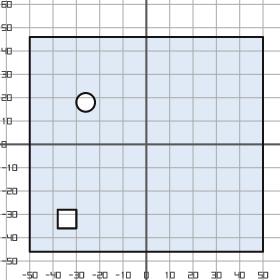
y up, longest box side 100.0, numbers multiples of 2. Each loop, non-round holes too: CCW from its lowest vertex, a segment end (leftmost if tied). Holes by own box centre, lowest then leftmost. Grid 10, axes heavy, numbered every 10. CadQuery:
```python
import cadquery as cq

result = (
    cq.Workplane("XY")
    .moveTo(-50.0, -46.0)
    .lineTo(50.0, -46.0)
    .lineTo(50.0, 46.0)
    .lineTo(-50.0, 46.0)
    .close()
    .moveTo(-38.0, -36.0)
    .lineTo(-30.0, -36.0)
    .lineTo(-30.0, -28.0)
    .lineTo(-38.0, -28.0)
    .close()
    .moveTo(-26.0, 18.0)
    .circle(4.0)
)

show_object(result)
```